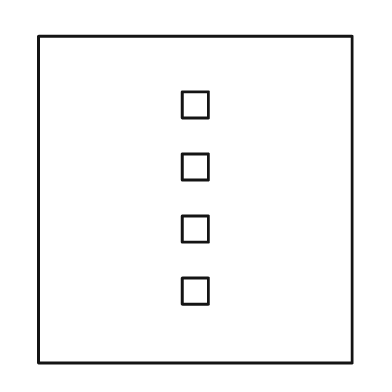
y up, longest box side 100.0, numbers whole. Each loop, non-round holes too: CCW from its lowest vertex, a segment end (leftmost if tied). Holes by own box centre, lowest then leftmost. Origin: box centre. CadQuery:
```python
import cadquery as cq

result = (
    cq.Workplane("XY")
    .moveTo(-48.0, -50.0)
    .lineTo(48.0, -50.0)
    .lineTo(48.0, 50.0)
    .lineTo(-48.0, 50.0)
    .close()
    .moveTo(-4.0, -32.0)
    .lineTo(4.0, -32.0)
    .lineTo(4.0, -24.0)
    .lineTo(-4.0, -24.0)
    .close()
    .moveTo(-4.0, -13.0)
    .lineTo(4.0, -13.0)
    .lineTo(4.0, -5.0)
    .lineTo(-4.0, -5.0)
    .close()
    .moveTo(-4.0, 6.0)
    .lineTo(4.0, 6.0)
    .lineTo(4.0, 14.0)
    .lineTo(-4.0, 14.0)
    .close()
    .moveTo(-4.0, 25.0)
    .lineTo(4.0, 25.0)
    .lineTo(4.0, 33.0)
    .lineTo(-4.0, 33.0)
    .close()
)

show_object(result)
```